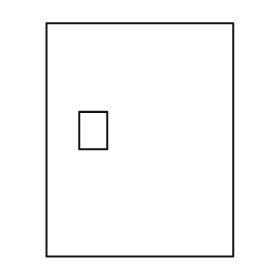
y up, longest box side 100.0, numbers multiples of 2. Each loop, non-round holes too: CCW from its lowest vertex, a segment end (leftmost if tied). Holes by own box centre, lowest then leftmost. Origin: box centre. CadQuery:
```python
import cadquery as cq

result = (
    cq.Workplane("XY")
    .moveTo(-40.0, -50.0)
    .lineTo(40.0, -50.0)
    .lineTo(40.0, 50.0)
    .lineTo(-40.0, 50.0)
    .close()
    .moveTo(-26.0, -4.0)
    .lineTo(-14.0, -4.0)
    .lineTo(-14.0, 12.0)
    .lineTo(-26.0, 12.0)
    .close()
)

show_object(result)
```